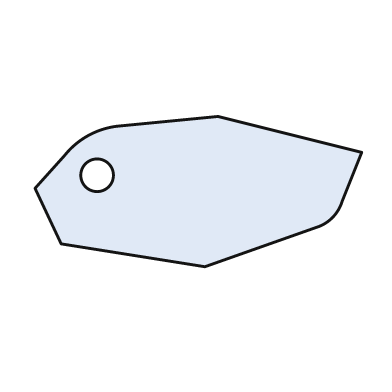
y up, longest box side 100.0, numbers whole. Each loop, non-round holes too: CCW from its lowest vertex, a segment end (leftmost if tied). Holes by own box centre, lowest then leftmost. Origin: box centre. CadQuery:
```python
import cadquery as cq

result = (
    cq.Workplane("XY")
    .moveTo(2.0, -23.0)
    .lineTo(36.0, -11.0)
    .threePointArc((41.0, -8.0), (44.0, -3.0))
    .lineTo(50.0, 12.0)
    .lineTo(6.0, 23.0)
    .lineTo(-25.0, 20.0)
    .threePointArc((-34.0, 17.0), (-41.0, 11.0))
    .lineTo(-50.0, 1.0)
    .lineTo(-42.0, -16.0)
    .close()
    .moveTo(-31.0, 5.0)
    .circle(5.0)
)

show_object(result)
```